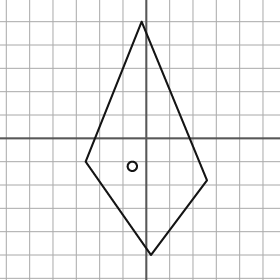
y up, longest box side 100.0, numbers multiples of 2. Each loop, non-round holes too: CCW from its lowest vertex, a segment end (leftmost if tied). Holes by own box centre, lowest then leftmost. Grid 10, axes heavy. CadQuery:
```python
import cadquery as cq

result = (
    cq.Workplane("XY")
    .moveTo(2.0, -50.0)
    .lineTo(26.0, -18.0)
    .lineTo(-2.0, 50.0)
    .lineTo(-26.0, -10.0)
    .close()
    .moveTo(-6.0, -12.0)
    .circle(2.0)
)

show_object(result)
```